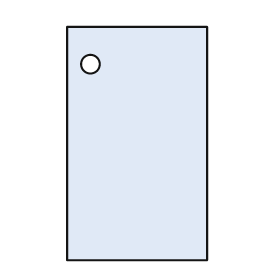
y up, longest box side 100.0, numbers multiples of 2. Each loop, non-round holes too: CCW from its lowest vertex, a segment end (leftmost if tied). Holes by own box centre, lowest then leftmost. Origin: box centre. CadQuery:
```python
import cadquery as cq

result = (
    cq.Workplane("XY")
    .moveTo(-30.0, -50.0)
    .lineTo(30.0, -50.0)
    .lineTo(30.0, 50.0)
    .lineTo(-30.0, 50.0)
    .close()
    .moveTo(-20.0, 34.0)
    .circle(4.0)
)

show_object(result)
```